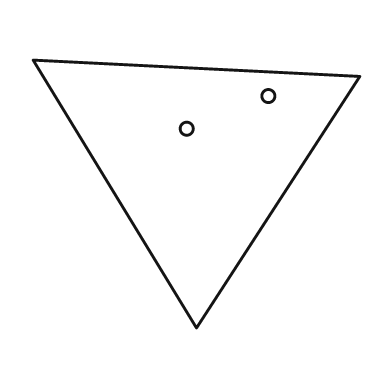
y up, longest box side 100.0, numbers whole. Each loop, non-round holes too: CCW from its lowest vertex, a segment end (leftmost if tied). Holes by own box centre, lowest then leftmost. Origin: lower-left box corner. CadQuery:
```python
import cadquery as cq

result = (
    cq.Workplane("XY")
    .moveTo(50.0, 0.0)
    .lineTo(100.0, 77.0)
    .lineTo(0.0, 82.0)
    .close()
    .moveTo(47.0, 61.0)
    .circle(2.0)
    .moveTo(72.0, 71.0)
    .circle(2.0)
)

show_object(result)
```